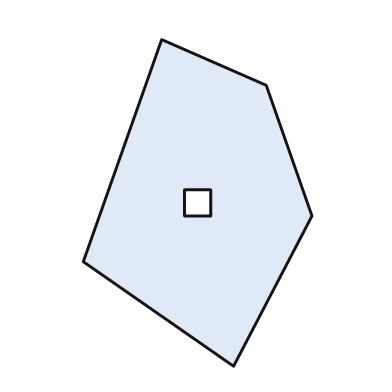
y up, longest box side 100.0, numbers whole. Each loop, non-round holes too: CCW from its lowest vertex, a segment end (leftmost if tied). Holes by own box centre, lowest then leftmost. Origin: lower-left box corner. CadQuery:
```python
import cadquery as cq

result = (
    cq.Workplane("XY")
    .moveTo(46.0, 0.0)
    .lineTo(70.0, 46.0)
    .lineTo(56.0, 86.0)
    .lineTo(24.0, 100.0)
    .lineTo(0.0, 32.0)
    .close()
    .moveTo(31.0, 46.0)
    .lineTo(39.0, 46.0)
    .lineTo(39.0, 54.0)
    .lineTo(31.0, 54.0)
    .close()
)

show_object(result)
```